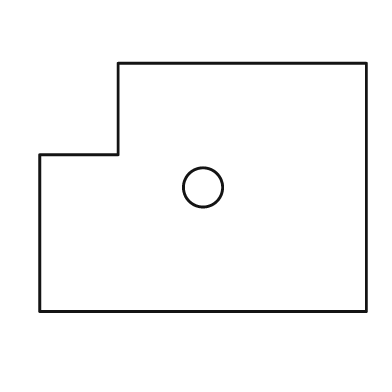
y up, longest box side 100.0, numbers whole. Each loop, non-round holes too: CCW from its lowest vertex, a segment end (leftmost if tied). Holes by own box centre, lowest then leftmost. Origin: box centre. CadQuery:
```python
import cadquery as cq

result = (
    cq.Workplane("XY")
    .moveTo(-50.0, -38.0)
    .lineTo(50.0, -38.0)
    .lineTo(50.0, 38.0)
    .lineTo(-26.0, 38.0)
    .lineTo(-26.0, 10.0)
    .lineTo(-50.0, 10.0)
    .close()
    .moveTo(0.0, 0.0)
    .circle(6.0)
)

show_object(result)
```